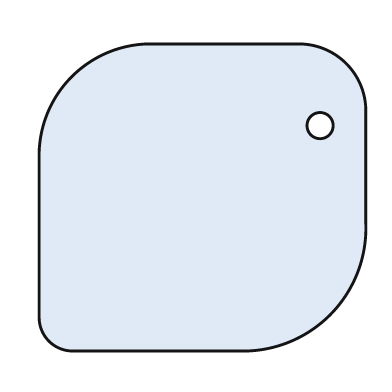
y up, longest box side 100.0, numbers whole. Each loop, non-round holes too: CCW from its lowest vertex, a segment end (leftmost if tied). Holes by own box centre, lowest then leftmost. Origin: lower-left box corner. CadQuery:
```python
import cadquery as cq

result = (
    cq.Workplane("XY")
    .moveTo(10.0, 0.0)
    .lineTo(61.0, 0.0)
    .threePointArc((89.0, 11.0), (100.0, 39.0))
    .lineTo(100.0, 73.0)
    .threePointArc((94.0, 88.0), (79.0, 94.0))
    .lineTo(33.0, 94.0)
    .threePointArc((10.0, 84.0), (0.0, 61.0))
    .lineTo(0.0, 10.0)
    .threePointArc((3.0, 3.0), (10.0, 0.0))
    .close()
    .moveTo(86.0, 69.0)
    .circle(4.0)
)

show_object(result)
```